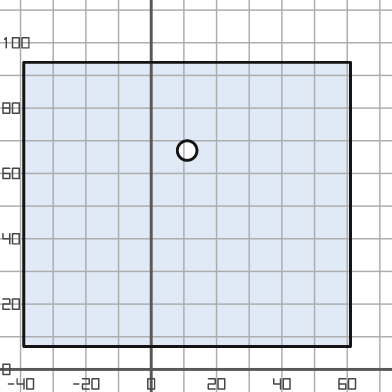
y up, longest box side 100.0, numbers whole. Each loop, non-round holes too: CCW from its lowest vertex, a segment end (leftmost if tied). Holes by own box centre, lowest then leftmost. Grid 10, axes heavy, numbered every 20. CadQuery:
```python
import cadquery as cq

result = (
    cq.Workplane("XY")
    .moveTo(-39.0, 7.0)
    .lineTo(61.0, 7.0)
    .lineTo(61.0, 94.0)
    .lineTo(-39.0, 94.0)
    .close()
    .moveTo(11.0, 67.0)
    .circle(3.0)
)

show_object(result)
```